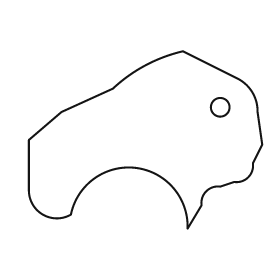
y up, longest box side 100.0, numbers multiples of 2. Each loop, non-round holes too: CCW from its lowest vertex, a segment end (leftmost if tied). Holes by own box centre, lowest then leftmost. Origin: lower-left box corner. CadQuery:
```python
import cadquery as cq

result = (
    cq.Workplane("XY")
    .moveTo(68.0, 0.0)
    .lineTo(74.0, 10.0)
    .threePointArc((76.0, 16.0), (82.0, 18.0))
    .lineTo(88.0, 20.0)
    .threePointArc((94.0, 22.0), (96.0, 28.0))
    .lineTo(100.0, 36.0)
    .lineTo(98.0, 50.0)
    .threePointArc((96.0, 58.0), (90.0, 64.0))
    .lineTo(66.0, 76.0)
    .threePointArc((50.0, 70.0), (36.0, 60.0))
    .lineTo(14.0, 50.0)
    .lineTo(0.0, 38.0)
    .lineTo(0.0, 16.0)
    .threePointArc((6.0, 6.0), (18.0, 6.0))
    .threePointArc((46.0, 26.0), (68.0, 0.0))
    .close()
    .moveTo(82.0, 52.0)
    .circle(4.0)
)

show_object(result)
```